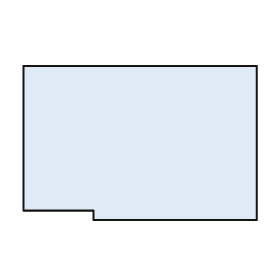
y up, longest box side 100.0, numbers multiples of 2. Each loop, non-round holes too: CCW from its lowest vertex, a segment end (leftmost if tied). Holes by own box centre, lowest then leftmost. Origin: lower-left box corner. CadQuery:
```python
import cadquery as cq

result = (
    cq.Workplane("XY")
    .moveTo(30.0, 0.0)
    .lineTo(100.0, 0.0)
    .lineTo(100.0, 66.0)
    .lineTo(0.0, 66.0)
    .lineTo(0.0, 4.0)
    .lineTo(30.0, 4.0)
    .close()
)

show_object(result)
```